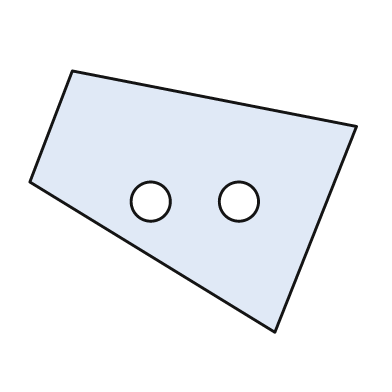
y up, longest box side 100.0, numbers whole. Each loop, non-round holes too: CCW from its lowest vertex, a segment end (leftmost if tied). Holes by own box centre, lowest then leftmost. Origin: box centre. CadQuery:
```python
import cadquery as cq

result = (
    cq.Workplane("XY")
    .moveTo(25.0, -40.0)
    .lineTo(50.0, 23.0)
    .lineTo(-37.0, 40.0)
    .lineTo(-50.0, 6.0)
    .close()
    .moveTo(-13.0, 0.0)
    .circle(6.0)
    .moveTo(14.0, 0.0)
    .circle(6.0)
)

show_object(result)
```